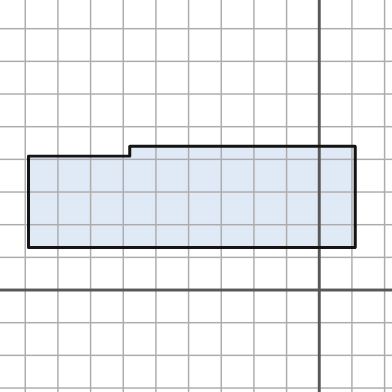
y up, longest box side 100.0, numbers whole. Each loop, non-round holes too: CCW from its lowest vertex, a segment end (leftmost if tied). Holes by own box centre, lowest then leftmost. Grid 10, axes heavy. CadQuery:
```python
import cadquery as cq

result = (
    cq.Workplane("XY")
    .moveTo(-89.0, 13.0)
    .lineTo(11.0, 13.0)
    .lineTo(11.0, 44.0)
    .lineTo(-58.0, 44.0)
    .lineTo(-58.0, 41.0)
    .lineTo(-89.0, 41.0)
    .close()
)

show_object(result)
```